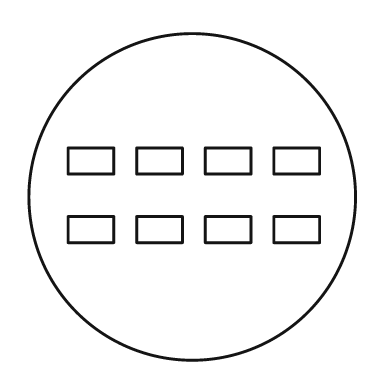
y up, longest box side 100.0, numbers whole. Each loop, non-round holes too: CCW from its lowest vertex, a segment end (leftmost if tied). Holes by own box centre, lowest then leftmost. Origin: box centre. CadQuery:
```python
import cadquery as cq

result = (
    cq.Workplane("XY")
    .moveTo(0.0, 0.0)
    .circle(50.0)
    .moveTo(-38.0, -14.0)
    .lineTo(-24.0, -14.0)
    .lineTo(-24.0, -6.0)
    .lineTo(-38.0, -6.0)
    .close()
    .moveTo(-17.0, -14.0)
    .lineTo(-3.0, -14.0)
    .lineTo(-3.0, -6.0)
    .lineTo(-17.0, -6.0)
    .close()
    .moveTo(4.0, -14.0)
    .lineTo(18.0, -14.0)
    .lineTo(18.0, -6.0)
    .lineTo(4.0, -6.0)
    .close()
    .moveTo(25.0, -14.0)
    .lineTo(39.0, -14.0)
    .lineTo(39.0, -6.0)
    .lineTo(25.0, -6.0)
    .close()
    .moveTo(-38.0, 7.0)
    .lineTo(-24.0, 7.0)
    .lineTo(-24.0, 15.0)
    .lineTo(-38.0, 15.0)
    .close()
    .moveTo(-17.0, 7.0)
    .lineTo(-3.0, 7.0)
    .lineTo(-3.0, 15.0)
    .lineTo(-17.0, 15.0)
    .close()
    .moveTo(4.0, 7.0)
    .lineTo(18.0, 7.0)
    .lineTo(18.0, 15.0)
    .lineTo(4.0, 15.0)
    .close()
    .moveTo(25.0, 7.0)
    .lineTo(39.0, 7.0)
    .lineTo(39.0, 15.0)
    .lineTo(25.0, 15.0)
    .close()
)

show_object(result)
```